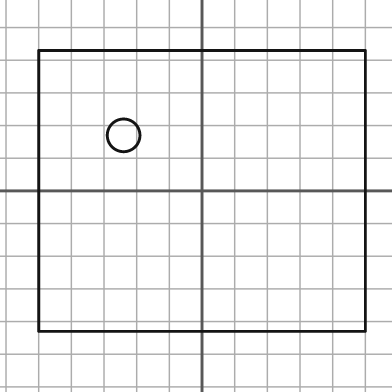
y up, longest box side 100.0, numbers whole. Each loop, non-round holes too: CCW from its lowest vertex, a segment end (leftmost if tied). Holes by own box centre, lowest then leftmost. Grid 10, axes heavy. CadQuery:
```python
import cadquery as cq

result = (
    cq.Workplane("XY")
    .moveTo(-50.0, -43.0)
    .lineTo(50.0, -43.0)
    .lineTo(50.0, 43.0)
    .lineTo(-50.0, 43.0)
    .close()
    .moveTo(-24.0, 17.0)
    .circle(5.0)
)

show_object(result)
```